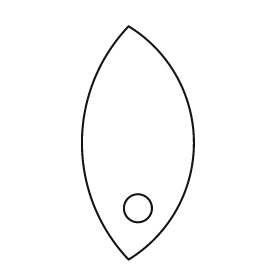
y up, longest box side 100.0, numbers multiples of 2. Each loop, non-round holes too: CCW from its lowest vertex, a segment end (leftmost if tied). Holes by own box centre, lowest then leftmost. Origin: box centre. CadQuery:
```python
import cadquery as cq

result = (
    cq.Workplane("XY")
    .moveTo(-4.0, -50.0)
    .threePointArc((24.0, 0.0), (-4.0, 50.0))
    .threePointArc((-24.0, 0.0), (-4.0, -50.0))
    .close()
    .moveTo(0.0, -28.0)
    .circle(6.0)
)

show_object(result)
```